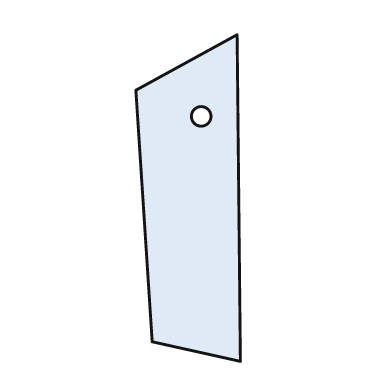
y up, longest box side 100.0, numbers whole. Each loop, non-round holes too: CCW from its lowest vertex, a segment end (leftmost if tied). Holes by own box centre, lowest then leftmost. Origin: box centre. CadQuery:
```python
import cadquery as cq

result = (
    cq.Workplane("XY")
    .moveTo(16.0, -50.0)
    .lineTo(15.0, 50.0)
    .lineTo(-16.0, 33.0)
    .lineTo(-11.0, -44.0)
    .close()
    .moveTo(4.0, 25.0)
    .circle(3.0)
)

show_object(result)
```